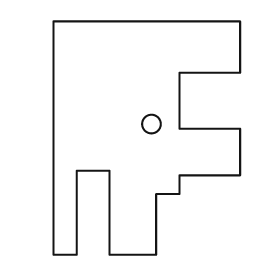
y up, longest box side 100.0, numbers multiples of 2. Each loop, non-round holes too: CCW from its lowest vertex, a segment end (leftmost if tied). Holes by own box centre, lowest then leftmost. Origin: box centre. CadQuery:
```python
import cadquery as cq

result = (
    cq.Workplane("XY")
    .moveTo(-40.0, -50.0)
    .lineTo(-30.0, -50.0)
    .lineTo(-30.0, -14.0)
    .lineTo(-16.0, -14.0)
    .lineTo(-16.0, -50.0)
    .lineTo(4.0, -50.0)
    .lineTo(4.0, -24.0)
    .lineTo(14.0, -24.0)
    .lineTo(14.0, -16.0)
    .lineTo(40.0, -16.0)
    .lineTo(40.0, 4.0)
    .lineTo(14.0, 4.0)
    .lineTo(14.0, 28.0)
    .lineTo(40.0, 28.0)
    .lineTo(40.0, 50.0)
    .lineTo(-40.0, 50.0)
    .close()
    .moveTo(2.0, 6.0)
    .circle(4.0)
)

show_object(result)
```